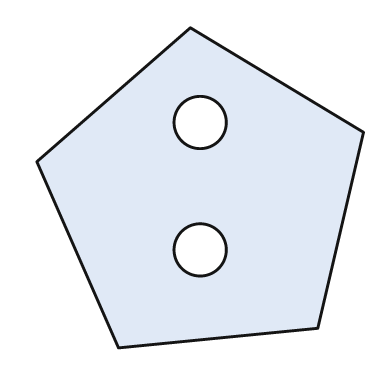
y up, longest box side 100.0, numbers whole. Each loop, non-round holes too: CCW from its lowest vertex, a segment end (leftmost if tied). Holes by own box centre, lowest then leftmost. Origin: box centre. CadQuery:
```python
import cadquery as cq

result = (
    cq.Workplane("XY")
    .moveTo(-25.0, -49.0)
    .lineTo(36.0, -43.0)
    .lineTo(50.0, 17.0)
    .lineTo(-3.0, 49.0)
    .lineTo(-50.0, 8.0)
    .close()
    .moveTo(0.0, -19.0)
    .circle(8.0)
    .moveTo(0.0, 20.0)
    .circle(8.0)
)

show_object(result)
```